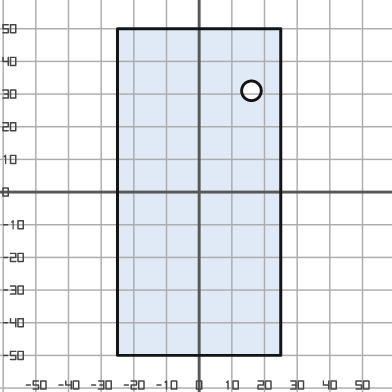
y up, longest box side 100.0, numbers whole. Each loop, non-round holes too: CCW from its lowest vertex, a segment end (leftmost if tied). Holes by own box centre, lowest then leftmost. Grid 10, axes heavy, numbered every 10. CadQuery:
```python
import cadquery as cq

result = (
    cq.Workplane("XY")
    .moveTo(-25.0, -50.0)
    .lineTo(25.0, -50.0)
    .lineTo(25.0, 50.0)
    .lineTo(-25.0, 50.0)
    .close()
    .moveTo(16.0, 31.0)
    .circle(3.0)
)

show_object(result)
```